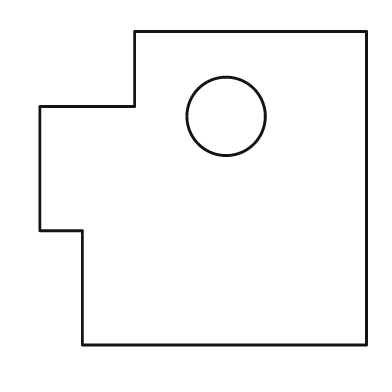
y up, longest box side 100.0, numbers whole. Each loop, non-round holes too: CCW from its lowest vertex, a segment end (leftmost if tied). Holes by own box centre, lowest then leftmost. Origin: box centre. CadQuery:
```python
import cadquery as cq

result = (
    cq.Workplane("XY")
    .moveTo(-37.0, -48.0)
    .lineTo(50.0, -48.0)
    .lineTo(50.0, 48.0)
    .lineTo(-21.0, 48.0)
    .lineTo(-21.0, 25.0)
    .lineTo(-50.0, 25.0)
    .lineTo(-50.0, -13.0)
    .lineTo(-37.0, -13.0)
    .close()
    .moveTo(7.0, 22.0)
    .circle(12.0)
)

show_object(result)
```